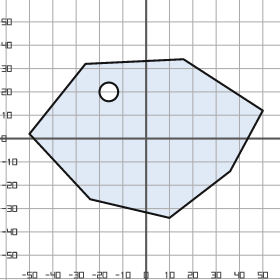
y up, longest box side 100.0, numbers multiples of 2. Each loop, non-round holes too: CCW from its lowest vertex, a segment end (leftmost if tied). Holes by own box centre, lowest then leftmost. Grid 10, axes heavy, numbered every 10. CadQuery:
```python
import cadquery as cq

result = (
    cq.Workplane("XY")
    .moveTo(10.0, -34.0)
    .lineTo(36.0, -14.0)
    .lineTo(50.0, 12.0)
    .lineTo(16.0, 34.0)
    .lineTo(-26.0, 32.0)
    .lineTo(-50.0, 2.0)
    .lineTo(-24.0, -26.0)
    .close()
    .moveTo(-16.0, 20.0)
    .circle(4.0)
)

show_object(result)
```